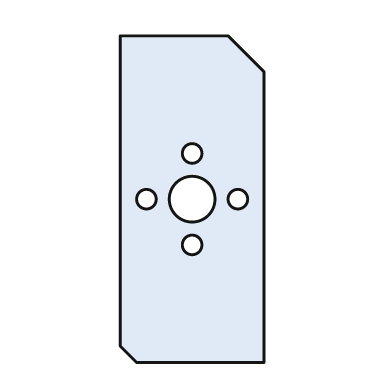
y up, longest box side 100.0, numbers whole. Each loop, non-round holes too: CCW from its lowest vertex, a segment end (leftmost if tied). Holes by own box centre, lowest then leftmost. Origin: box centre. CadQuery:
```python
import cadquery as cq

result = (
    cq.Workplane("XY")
    .moveTo(-17.0, -50.0)
    .lineTo(22.0, -50.0)
    .lineTo(22.0, 39.0)
    .lineTo(11.0, 50.0)
    .lineTo(-22.0, 50.0)
    .lineTo(-22.0, -45.0)
    .close()
    .moveTo(0.0, -14.0)
    .circle(3.0)
    .moveTo(-14.0, 0.0)
    .circle(3.0)
    .moveTo(0.0, 0.0)
    .circle(7.0)
    .moveTo(14.0, 0.0)
    .circle(3.0)
    .moveTo(0.0, 14.0)
    .circle(3.0)
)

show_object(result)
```